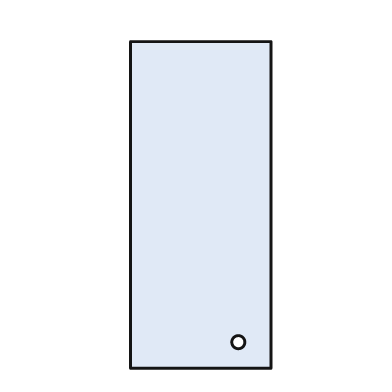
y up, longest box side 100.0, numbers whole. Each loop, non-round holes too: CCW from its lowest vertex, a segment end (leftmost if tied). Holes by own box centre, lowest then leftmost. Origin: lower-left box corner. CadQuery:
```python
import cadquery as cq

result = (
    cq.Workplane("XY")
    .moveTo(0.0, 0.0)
    .lineTo(43.0, 0.0)
    .lineTo(43.0, 100.0)
    .lineTo(0.0, 100.0)
    .close()
    .moveTo(33.0, 8.0)
    .circle(2.0)
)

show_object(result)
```